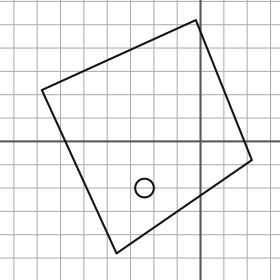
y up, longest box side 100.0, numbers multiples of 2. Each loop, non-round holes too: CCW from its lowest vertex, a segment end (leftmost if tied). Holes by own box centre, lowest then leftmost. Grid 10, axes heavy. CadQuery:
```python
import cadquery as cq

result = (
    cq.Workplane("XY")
    .moveTo(-36.0, -48.0)
    .lineTo(22.0, -8.0)
    .lineTo(-2.0, 52.0)
    .lineTo(-68.0, 22.0)
    .close()
    .moveTo(-24.0, -20.0)
    .circle(4.0)
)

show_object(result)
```